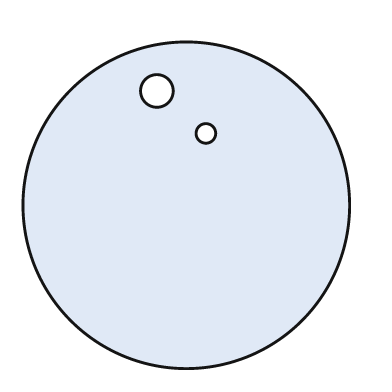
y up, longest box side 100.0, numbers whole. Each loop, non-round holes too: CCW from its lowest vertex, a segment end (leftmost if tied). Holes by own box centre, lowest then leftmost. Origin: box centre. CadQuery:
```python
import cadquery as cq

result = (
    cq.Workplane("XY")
    .moveTo(0.0, 0.0)
    .circle(50.0)
    .moveTo(6.0, 22.0)
    .circle(3.0)
    .moveTo(-9.0, 35.0)
    .circle(5.0)
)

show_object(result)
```